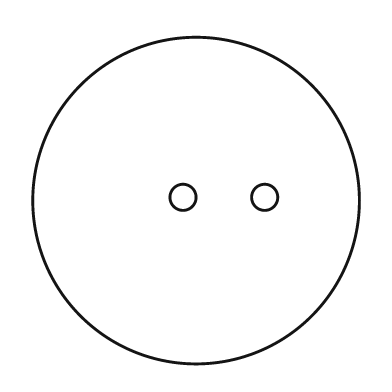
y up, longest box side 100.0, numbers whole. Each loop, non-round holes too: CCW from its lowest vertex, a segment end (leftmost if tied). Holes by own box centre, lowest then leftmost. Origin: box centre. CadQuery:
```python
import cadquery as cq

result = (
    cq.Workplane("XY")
    .moveTo(0.0, 0.0)
    .circle(50.0)
    .moveTo(-4.0, 1.0)
    .circle(4.0)
    .moveTo(21.0, 1.0)
    .circle(4.0)
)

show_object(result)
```